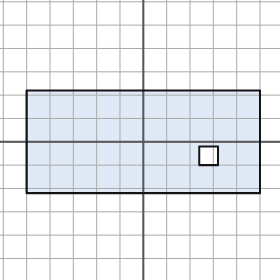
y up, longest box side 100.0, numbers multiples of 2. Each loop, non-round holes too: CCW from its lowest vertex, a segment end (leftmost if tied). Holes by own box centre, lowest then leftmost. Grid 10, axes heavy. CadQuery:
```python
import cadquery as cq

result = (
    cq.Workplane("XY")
    .moveTo(-50.0, -22.0)
    .lineTo(50.0, -22.0)
    .lineTo(50.0, 22.0)
    .lineTo(-50.0, 22.0)
    .close()
    .moveTo(24.0, -10.0)
    .lineTo(32.0, -10.0)
    .lineTo(32.0, -2.0)
    .lineTo(24.0, -2.0)
    .close()
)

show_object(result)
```